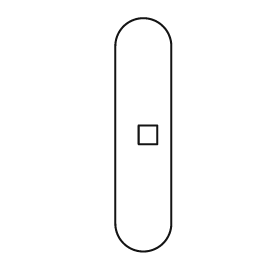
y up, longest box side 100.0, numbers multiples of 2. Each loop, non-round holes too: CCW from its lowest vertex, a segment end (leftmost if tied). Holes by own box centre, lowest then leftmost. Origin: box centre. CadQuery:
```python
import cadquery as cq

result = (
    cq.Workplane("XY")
    .moveTo(-12.0, -38.0)
    .threePointArc((0.0, -50.0), (12.0, -38.0))
    .lineTo(12.0, 38.0)
    .threePointArc((0.0, 50.0), (-12.0, 38.0))
    .close()
    .moveTo(-2.0, -4.0)
    .lineTo(6.0, -4.0)
    .lineTo(6.0, 4.0)
    .lineTo(-2.0, 4.0)
    .close()
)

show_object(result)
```